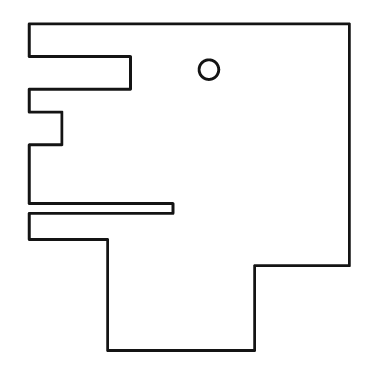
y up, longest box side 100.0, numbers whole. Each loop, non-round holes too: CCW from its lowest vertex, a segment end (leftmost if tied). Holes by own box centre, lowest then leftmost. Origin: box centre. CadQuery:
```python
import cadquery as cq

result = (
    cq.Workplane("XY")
    .moveTo(-25.0, -50.0)
    .lineTo(20.0, -50.0)
    .lineTo(20.0, -24.0)
    .lineTo(49.0, -24.0)
    .lineTo(49.0, 50.0)
    .lineTo(-49.0, 50.0)
    .lineTo(-49.0, 40.0)
    .lineTo(-18.0, 40.0)
    .lineTo(-18.0, 30.0)
    .lineTo(-49.0, 30.0)
    .lineTo(-49.0, 23.0)
    .lineTo(-39.0, 23.0)
    .lineTo(-39.0, 13.0)
    .lineTo(-49.0, 13.0)
    .lineTo(-49.0, -5.0)
    .lineTo(-5.0, -5.0)
    .lineTo(-5.0, -8.0)
    .lineTo(-49.0, -8.0)
    .lineTo(-49.0, -16.0)
    .lineTo(-25.0, -16.0)
    .close()
    .moveTo(6.0, 36.0)
    .circle(3.0)
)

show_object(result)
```